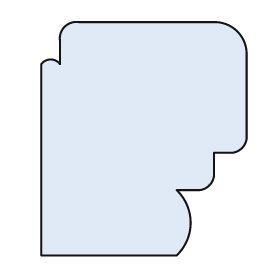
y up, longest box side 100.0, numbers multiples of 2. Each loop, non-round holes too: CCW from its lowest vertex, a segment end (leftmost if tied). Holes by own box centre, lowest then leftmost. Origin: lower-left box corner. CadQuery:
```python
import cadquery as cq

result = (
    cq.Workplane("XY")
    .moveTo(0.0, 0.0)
    .lineTo(58.0, 0.0)
    .threePointArc((64.0, 14.0), (58.0, 28.0))
    .lineTo(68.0, 28.0)
    .threePointArc((72.0, 30.0), (74.0, 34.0))
    .lineTo(74.0, 44.0)
    .lineTo(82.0, 44.0)
    .threePointArc((86.0, 46.0), (88.0, 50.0))
    .lineTo(88.0, 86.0)
    .threePointArc((84.0, 96.0), (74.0, 100.0))
    .lineTo(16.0, 100.0)
    .threePointArc((10.0, 98.0), (8.0, 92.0))
    .lineTo(8.0, 82.0)
    .threePointArc((4.0, 84.0), (0.0, 82.0))
    .close()
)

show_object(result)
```